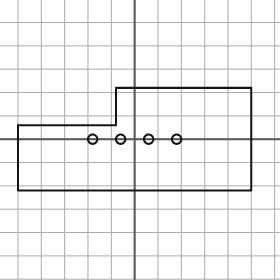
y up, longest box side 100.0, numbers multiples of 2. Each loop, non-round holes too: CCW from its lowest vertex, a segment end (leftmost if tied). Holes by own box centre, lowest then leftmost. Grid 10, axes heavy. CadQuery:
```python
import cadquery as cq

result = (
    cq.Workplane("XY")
    .moveTo(-50.0, -22.0)
    .lineTo(50.0, -22.0)
    .lineTo(50.0, 22.0)
    .lineTo(-8.0, 22.0)
    .lineTo(-8.0, 6.0)
    .lineTo(-50.0, 6.0)
    .close()
    .moveTo(-18.0, 0.0)
    .circle(2.0)
    .moveTo(-6.0, 0.0)
    .circle(2.0)
    .moveTo(6.0, 0.0)
    .circle(2.0)
    .moveTo(18.0, 0.0)
    .circle(2.0)
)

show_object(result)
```